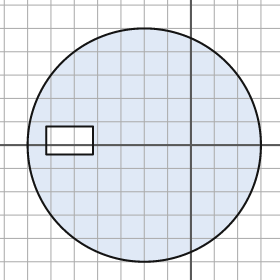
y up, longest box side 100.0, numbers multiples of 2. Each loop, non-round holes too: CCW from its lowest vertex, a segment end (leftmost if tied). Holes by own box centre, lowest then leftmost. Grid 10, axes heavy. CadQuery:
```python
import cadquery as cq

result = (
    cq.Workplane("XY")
    .moveTo(-20.0, 0.0)
    .circle(50.0)
    .moveTo(-62.0, -4.0)
    .lineTo(-42.0, -4.0)
    .lineTo(-42.0, 8.0)
    .lineTo(-62.0, 8.0)
    .close()
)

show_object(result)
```